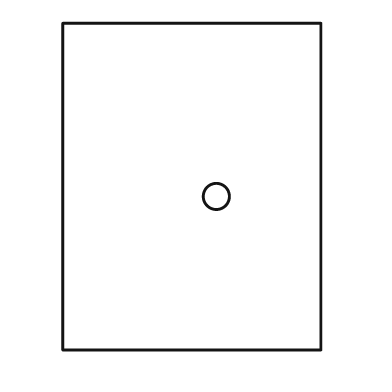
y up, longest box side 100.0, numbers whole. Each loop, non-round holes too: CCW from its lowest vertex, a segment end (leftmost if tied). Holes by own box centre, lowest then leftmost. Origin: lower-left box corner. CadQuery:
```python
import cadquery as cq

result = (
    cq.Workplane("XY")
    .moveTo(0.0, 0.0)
    .lineTo(79.0, 0.0)
    .lineTo(79.0, 100.0)
    .lineTo(0.0, 100.0)
    .close()
    .moveTo(47.0, 47.0)
    .circle(4.0)
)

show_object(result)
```